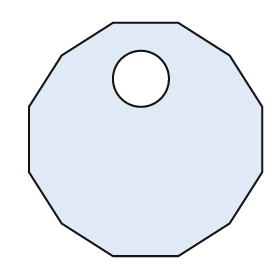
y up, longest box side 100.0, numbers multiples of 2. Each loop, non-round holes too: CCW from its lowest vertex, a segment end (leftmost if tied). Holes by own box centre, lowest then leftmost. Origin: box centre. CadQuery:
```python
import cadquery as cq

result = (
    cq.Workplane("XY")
    .moveTo(-14.0, -50.0)
    .lineTo(14.0, -50.0)
    .lineTo(36.0, -36.0)
    .lineTo(50.0, -14.0)
    .lineTo(50.0, 14.0)
    .lineTo(36.0, 36.0)
    .lineTo(14.0, 50.0)
    .lineTo(-14.0, 50.0)
    .lineTo(-36.0, 36.0)
    .lineTo(-50.0, 14.0)
    .lineTo(-50.0, -14.0)
    .lineTo(-36.0, -36.0)
    .close()
    .moveTo(-2.0, 26.0)
    .circle(12.0)
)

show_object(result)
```